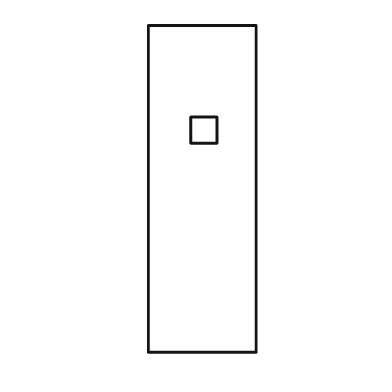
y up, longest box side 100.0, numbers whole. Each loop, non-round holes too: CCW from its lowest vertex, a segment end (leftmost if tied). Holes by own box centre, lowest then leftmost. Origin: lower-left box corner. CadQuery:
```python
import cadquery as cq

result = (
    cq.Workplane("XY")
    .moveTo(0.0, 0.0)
    .lineTo(33.0, 0.0)
    .lineTo(33.0, 100.0)
    .lineTo(0.0, 100.0)
    .close()
    .moveTo(13.0, 64.0)
    .lineTo(21.0, 64.0)
    .lineTo(21.0, 72.0)
    .lineTo(13.0, 72.0)
    .close()
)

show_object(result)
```